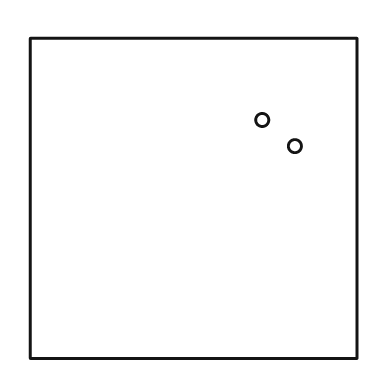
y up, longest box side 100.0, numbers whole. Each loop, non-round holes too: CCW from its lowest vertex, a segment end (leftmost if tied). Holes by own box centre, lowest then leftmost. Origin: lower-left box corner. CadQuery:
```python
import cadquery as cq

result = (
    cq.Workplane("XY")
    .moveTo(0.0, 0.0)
    .lineTo(100.0, 0.0)
    .lineTo(100.0, 98.0)
    .lineTo(0.0, 98.0)
    .close()
    .moveTo(81.0, 65.0)
    .circle(2.0)
    .moveTo(71.0, 73.0)
    .circle(2.0)
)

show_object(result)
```